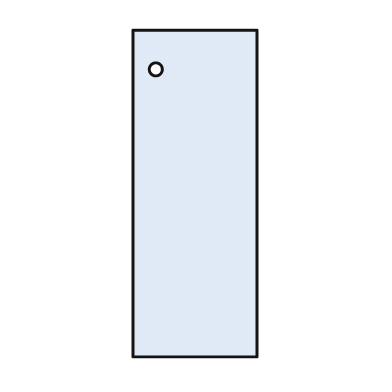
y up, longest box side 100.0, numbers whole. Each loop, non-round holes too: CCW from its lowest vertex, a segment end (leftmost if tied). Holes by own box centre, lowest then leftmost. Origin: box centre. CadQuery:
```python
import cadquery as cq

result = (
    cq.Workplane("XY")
    .moveTo(-19.0, -50.0)
    .lineTo(19.0, -50.0)
    .lineTo(19.0, 50.0)
    .lineTo(-19.0, 50.0)
    .close()
    .moveTo(-12.0, 38.0)
    .circle(2.0)
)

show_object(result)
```